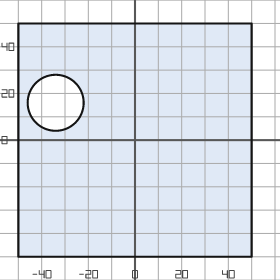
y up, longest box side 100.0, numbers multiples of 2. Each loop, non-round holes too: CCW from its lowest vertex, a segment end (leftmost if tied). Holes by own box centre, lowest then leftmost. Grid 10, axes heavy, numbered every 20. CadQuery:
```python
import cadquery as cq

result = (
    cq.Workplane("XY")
    .moveTo(-50.0, -50.0)
    .lineTo(50.0, -50.0)
    .lineTo(50.0, 50.0)
    .lineTo(-50.0, 50.0)
    .close()
    .moveTo(-34.0, 16.0)
    .circle(12.0)
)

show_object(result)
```